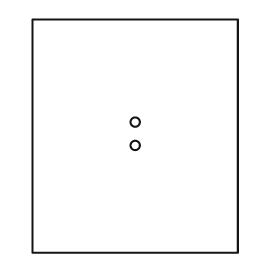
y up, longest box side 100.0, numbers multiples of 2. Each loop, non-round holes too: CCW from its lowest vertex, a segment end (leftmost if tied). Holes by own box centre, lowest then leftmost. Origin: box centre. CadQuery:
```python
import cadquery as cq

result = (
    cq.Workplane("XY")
    .moveTo(-44.0, -50.0)
    .lineTo(44.0, -50.0)
    .lineTo(44.0, 50.0)
    .lineTo(-44.0, 50.0)
    .close()
    .moveTo(0.0, -4.0)
    .circle(2.0)
    .moveTo(0.0, 6.0)
    .circle(2.0)
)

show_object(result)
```